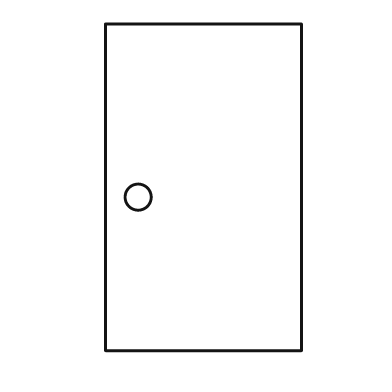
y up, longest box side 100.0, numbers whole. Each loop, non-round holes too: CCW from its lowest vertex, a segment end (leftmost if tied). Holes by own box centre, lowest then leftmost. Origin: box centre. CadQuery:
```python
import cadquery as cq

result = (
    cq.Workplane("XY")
    .moveTo(-30.0, -50.0)
    .lineTo(30.0, -50.0)
    .lineTo(30.0, 50.0)
    .lineTo(-30.0, 50.0)
    .close()
    .moveTo(-20.0, -3.0)
    .circle(4.0)
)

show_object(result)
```